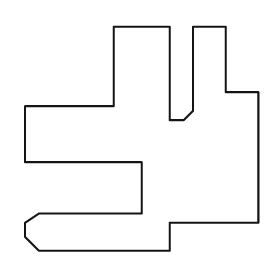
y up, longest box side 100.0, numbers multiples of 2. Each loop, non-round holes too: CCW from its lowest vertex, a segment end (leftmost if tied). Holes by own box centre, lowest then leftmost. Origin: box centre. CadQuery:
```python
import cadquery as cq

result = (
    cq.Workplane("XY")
    .moveTo(-44.0, -48.0)
    .lineTo(12.0, -48.0)
    .lineTo(12.0, -36.0)
    .lineTo(50.0, -36.0)
    .lineTo(50.0, 20.0)
    .lineTo(36.0, 20.0)
    .lineTo(36.0, 48.0)
    .lineTo(22.0, 48.0)
    .lineTo(22.0, 12.0)
    .lineTo(18.0, 8.0)
    .lineTo(12.0, 8.0)
    .lineTo(12.0, 48.0)
    .lineTo(-12.0, 48.0)
    .lineTo(-12.0, 14.0)
    .lineTo(-50.0, 14.0)
    .lineTo(-50.0, -10.0)
    .lineTo(0.0, -10.0)
    .lineTo(0.0, -32.0)
    .lineTo(-44.0, -32.0)
    .lineTo(-50.0, -36.0)
    .lineTo(-50.0, -42.0)
    .close()
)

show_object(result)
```